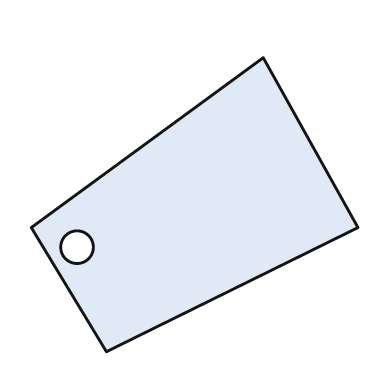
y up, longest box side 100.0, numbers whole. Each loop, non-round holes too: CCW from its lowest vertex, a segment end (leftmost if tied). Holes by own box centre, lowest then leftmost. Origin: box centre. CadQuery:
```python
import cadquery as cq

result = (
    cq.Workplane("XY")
    .moveTo(-27.0, -45.0)
    .lineTo(50.0, -7.0)
    .lineTo(21.0, 45.0)
    .lineTo(-50.0, -7.0)
    .close()
    .moveTo(-36.0, -13.0)
    .circle(5.0)
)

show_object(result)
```